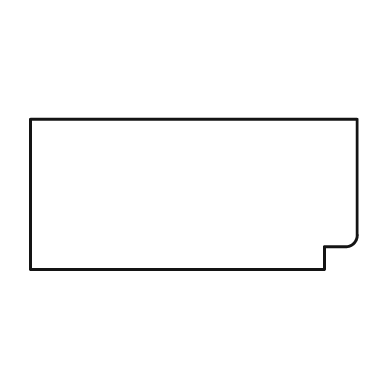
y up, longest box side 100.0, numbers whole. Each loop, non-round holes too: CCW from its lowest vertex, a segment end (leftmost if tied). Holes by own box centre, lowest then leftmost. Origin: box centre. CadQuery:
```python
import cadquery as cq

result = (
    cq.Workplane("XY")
    .moveTo(-50.0, -23.0)
    .lineTo(40.0, -23.0)
    .lineTo(40.0, -16.0)
    .lineTo(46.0, -16.0)
    .threePointArc((49.0, -15.0), (50.0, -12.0))
    .lineTo(50.0, 23.0)
    .lineTo(-50.0, 23.0)
    .close()
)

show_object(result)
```